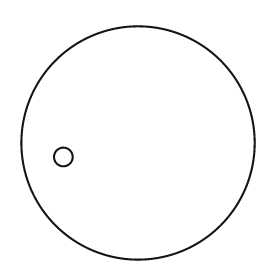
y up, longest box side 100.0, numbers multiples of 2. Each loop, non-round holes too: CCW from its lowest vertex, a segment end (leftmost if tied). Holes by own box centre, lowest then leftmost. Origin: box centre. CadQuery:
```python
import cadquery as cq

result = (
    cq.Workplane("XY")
    .moveTo(0.0, 0.0)
    .circle(50.0)
    .moveTo(-32.0, -6.0)
    .circle(4.0)
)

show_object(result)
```